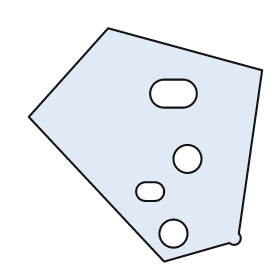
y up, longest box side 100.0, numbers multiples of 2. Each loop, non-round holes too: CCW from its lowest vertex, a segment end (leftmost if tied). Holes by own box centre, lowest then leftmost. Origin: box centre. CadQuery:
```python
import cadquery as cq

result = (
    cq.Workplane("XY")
    .moveTo(8.0, -50.0)
    .lineTo(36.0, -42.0)
    .threePointArc((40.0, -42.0), (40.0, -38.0))
    .lineTo(50.0, 32.0)
    .lineTo(-16.0, 50.0)
    .lineTo(-50.0, 12.0)
    .close()
    .moveTo(12.0, -38.0)
    .circle(6.0)
    .moveTo(0.0, -24.0)
    .lineTo(4.0, -24.0)
    .threePointArc((8.0, -20.0), (4.0, -16.0))
    .lineTo(0.0, -16.0)
    .threePointArc((-4.0, -20.0), (0.0, -24.0))
    .close()
    .moveTo(18.0, -6.0)
    .circle(6.0)
    .moveTo(8.0, 16.0)
    .lineTo(16.0, 16.0)
    .threePointArc((22.0, 22.0), (16.0, 28.0))
    .lineTo(8.0, 28.0)
    .threePointArc((2.0, 22.0), (8.0, 16.0))
    .close()
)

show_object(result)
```